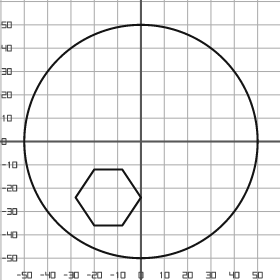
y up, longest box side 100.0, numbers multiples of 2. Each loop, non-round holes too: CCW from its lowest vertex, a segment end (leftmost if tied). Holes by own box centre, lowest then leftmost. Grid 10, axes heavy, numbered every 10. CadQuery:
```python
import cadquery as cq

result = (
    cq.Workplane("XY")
    .moveTo(0.0, 0.0)
    .circle(50.0)
    .moveTo(-20.0, -36.0)
    .lineTo(-8.0, -36.0)
    .lineTo(0.0, -24.0)
    .lineTo(-8.0, -12.0)
    .lineTo(-20.0, -12.0)
    .lineTo(-28.0, -24.0)
    .close()
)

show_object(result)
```